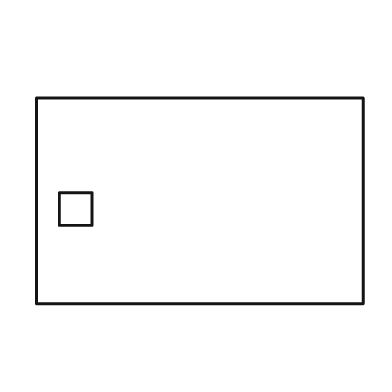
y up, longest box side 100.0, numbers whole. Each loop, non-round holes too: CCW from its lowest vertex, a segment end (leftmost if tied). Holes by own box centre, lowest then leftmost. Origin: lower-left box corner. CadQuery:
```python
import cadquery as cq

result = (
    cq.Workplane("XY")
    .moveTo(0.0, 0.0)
    .lineTo(100.0, 0.0)
    .lineTo(100.0, 63.0)
    .lineTo(0.0, 63.0)
    .close()
    .moveTo(7.0, 24.0)
    .lineTo(17.0, 24.0)
    .lineTo(17.0, 34.0)
    .lineTo(7.0, 34.0)
    .close()
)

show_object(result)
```